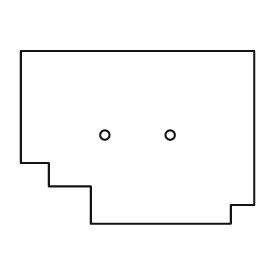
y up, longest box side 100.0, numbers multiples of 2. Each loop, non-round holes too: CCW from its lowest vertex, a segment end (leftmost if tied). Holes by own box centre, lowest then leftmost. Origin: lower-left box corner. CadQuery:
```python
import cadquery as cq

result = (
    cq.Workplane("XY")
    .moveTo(30.0, 0.0)
    .lineTo(90.0, 0.0)
    .lineTo(90.0, 8.0)
    .lineTo(100.0, 8.0)
    .lineTo(100.0, 74.0)
    .lineTo(0.0, 74.0)
    .lineTo(0.0, 26.0)
    .lineTo(12.0, 26.0)
    .lineTo(12.0, 16.0)
    .lineTo(30.0, 16.0)
    .close()
    .moveTo(36.0, 38.0)
    .circle(2.0)
    .moveTo(64.0, 38.0)
    .circle(2.0)
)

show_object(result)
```